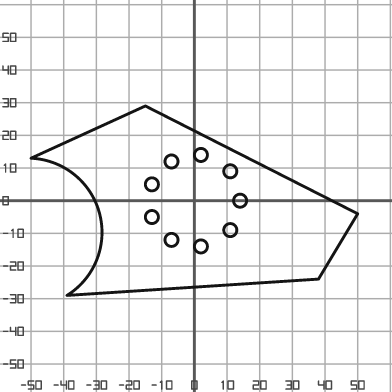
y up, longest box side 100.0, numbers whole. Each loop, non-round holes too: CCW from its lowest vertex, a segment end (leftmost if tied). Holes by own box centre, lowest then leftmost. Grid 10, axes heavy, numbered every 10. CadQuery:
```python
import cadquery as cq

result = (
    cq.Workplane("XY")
    .moveTo(-39.0, -29.0)
    .lineTo(38.0, -24.0)
    .lineTo(50.0, -4.0)
    .lineTo(-15.0, 29.0)
    .lineTo(-50.0, 13.0)
    .threePointArc((-29.0, -4.0), (-39.0, -29.0))
    .close()
    .moveTo(2.0, -14.0)
    .circle(2.0)
    .moveTo(-7.0, -12.0)
    .circle(2.0)
    .moveTo(11.0, -9.0)
    .circle(2.0)
    .moveTo(-13.0, -5.0)
    .circle(2.0)
    .moveTo(14.0, 0.0)
    .circle(2.0)
    .moveTo(-13.0, 5.0)
    .circle(2.0)
    .moveTo(11.0, 9.0)
    .circle(2.0)
    .moveTo(-7.0, 12.0)
    .circle(2.0)
    .moveTo(2.0, 14.0)
    .circle(2.0)
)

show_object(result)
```